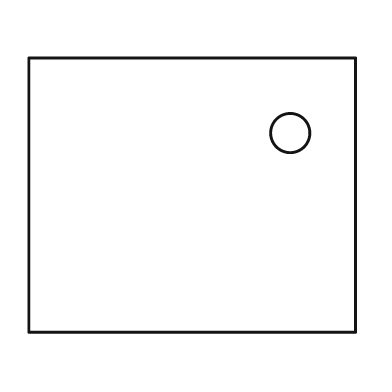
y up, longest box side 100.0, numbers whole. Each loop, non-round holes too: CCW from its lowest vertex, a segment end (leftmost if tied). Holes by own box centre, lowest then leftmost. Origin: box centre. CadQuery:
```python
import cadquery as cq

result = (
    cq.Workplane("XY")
    .moveTo(-50.0, -42.0)
    .lineTo(50.0, -42.0)
    .lineTo(50.0, 42.0)
    .lineTo(-50.0, 42.0)
    .close()
    .moveTo(30.0, 19.0)
    .circle(6.0)
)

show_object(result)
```